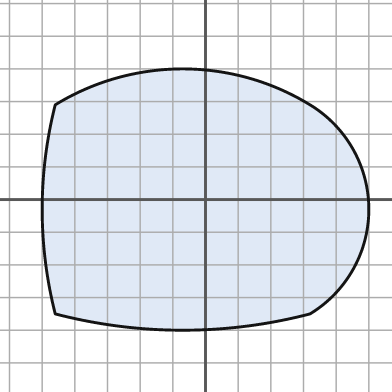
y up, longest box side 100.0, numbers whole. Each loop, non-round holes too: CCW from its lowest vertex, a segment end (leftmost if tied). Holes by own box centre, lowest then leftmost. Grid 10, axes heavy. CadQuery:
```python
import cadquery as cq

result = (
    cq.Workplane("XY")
    .moveTo(-46.0, -35.0)
    .threePointArc((-7.0, -40.0), (32.0, -35.0))
    .threePointArc((50.0, -3.0), (32.0, 29.0))
    .threePointArc((-7.0, 40.0), (-46.0, 29.0))
    .threePointArc((-50.0, -3.0), (-46.0, -35.0))
    .close()
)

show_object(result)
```